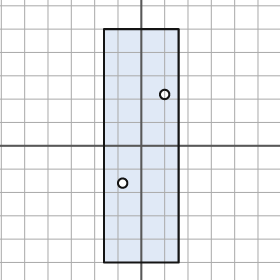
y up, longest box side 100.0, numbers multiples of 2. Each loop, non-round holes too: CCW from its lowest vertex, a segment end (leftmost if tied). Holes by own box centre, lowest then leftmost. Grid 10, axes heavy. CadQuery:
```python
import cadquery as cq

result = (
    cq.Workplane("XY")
    .moveTo(-16.0, -50.0)
    .lineTo(16.0, -50.0)
    .lineTo(16.0, 50.0)
    .lineTo(-16.0, 50.0)
    .close()
    .moveTo(-8.0, -16.0)
    .circle(2.0)
    .moveTo(10.0, 22.0)
    .circle(2.0)
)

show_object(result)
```